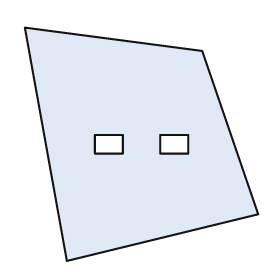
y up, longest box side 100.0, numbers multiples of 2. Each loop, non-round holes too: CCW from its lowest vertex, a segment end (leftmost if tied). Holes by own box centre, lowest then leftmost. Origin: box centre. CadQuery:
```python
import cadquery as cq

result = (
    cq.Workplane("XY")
    .moveTo(-32.0, -50.0)
    .lineTo(50.0, -30.0)
    .lineTo(26.0, 40.0)
    .lineTo(-50.0, 50.0)
    .close()
    .moveTo(-20.0, -4.0)
    .lineTo(-8.0, -4.0)
    .lineTo(-8.0, 4.0)
    .lineTo(-20.0, 4.0)
    .close()
    .moveTo(8.0, -4.0)
    .lineTo(20.0, -4.0)
    .lineTo(20.0, 4.0)
    .lineTo(8.0, 4.0)
    .close()
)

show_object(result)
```